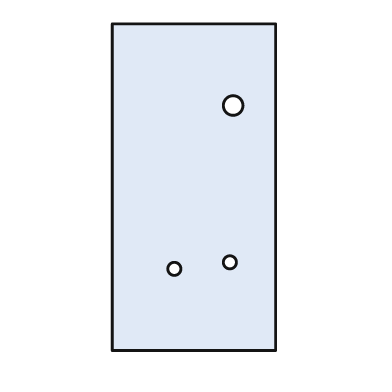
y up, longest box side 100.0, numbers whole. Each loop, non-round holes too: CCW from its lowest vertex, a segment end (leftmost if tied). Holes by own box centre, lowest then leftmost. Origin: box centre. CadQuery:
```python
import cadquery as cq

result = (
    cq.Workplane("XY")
    .moveTo(-25.0, -50.0)
    .lineTo(25.0, -50.0)
    .lineTo(25.0, 50.0)
    .lineTo(-25.0, 50.0)
    .close()
    .moveTo(-6.0, -25.0)
    .circle(2.0)
    .moveTo(11.0, -23.0)
    .circle(2.0)
    .moveTo(12.0, 25.0)
    .circle(3.0)
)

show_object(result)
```